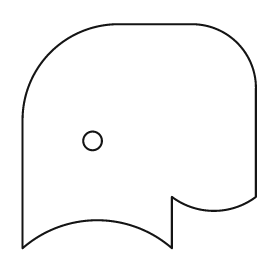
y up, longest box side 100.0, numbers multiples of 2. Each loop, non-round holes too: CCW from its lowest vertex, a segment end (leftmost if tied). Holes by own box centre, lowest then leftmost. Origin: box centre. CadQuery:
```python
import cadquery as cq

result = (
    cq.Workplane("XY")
    .moveTo(-50.0, -48.0)
    .threePointArc((-18.0, -36.0), (14.0, -48.0))
    .lineTo(14.0, -26.0)
    .threePointArc((32.0, -32.0), (50.0, -26.0))
    .lineTo(50.0, 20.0)
    .threePointArc((42.0, 40.0), (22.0, 48.0))
    .lineTo(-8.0, 48.0)
    .threePointArc((-38.0, 36.0), (-50.0, 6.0))
    .close()
    .moveTo(-20.0, -2.0)
    .circle(4.0)
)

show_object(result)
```